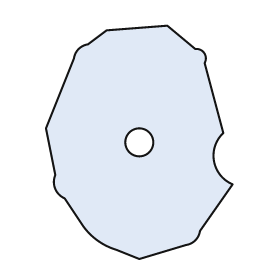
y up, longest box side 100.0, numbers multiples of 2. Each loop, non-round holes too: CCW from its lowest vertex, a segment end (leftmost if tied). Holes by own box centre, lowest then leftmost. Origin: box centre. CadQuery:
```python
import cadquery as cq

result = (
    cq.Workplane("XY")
    .moveTo(0.0, -50.0)
    .lineTo(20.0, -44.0)
    .threePointArc((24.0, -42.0), (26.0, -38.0))
    .lineTo(40.0, -18.0)
    .threePointArc((32.0, -8.0), (36.0, 4.0))
    .lineTo(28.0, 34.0)
    .threePointArc((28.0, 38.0), (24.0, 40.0))
    .lineTo(12.0, 50.0)
    .lineTo(-14.0, 48.0)
    .lineTo(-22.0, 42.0)
    .threePointArc((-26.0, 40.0), (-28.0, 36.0))
    .lineTo(-40.0, 6.0)
    .lineTo(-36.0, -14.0)
    .threePointArc((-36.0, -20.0), (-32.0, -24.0))
    .lineTo(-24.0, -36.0)
    .threePointArc((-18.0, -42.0), (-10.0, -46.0))
    .close()
    .moveTo(0.0, 0.0)
    .circle(6.0)
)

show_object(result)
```